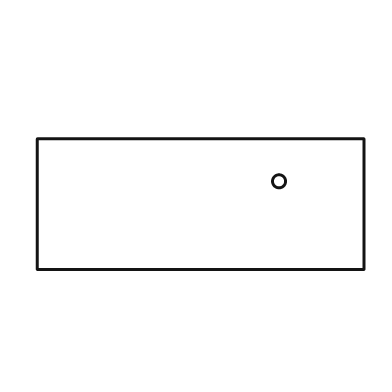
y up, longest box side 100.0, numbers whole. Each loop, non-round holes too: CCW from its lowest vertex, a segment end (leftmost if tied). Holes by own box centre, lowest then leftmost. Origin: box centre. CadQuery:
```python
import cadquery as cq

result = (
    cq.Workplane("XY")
    .moveTo(-50.0, -20.0)
    .lineTo(50.0, -20.0)
    .lineTo(50.0, 20.0)
    .lineTo(-50.0, 20.0)
    .close()
    .moveTo(24.0, 7.0)
    .circle(2.0)
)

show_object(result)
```